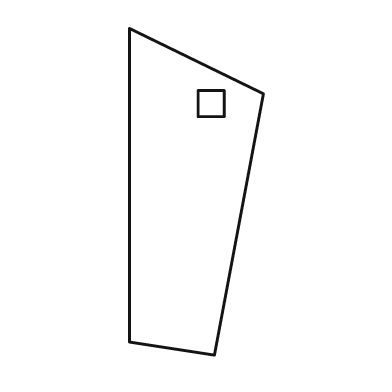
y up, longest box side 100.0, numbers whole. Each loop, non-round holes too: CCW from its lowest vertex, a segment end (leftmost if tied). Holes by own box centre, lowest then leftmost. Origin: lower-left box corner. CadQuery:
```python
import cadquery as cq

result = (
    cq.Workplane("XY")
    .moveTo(26.0, 0.0)
    .lineTo(41.0, 80.0)
    .lineTo(0.0, 100.0)
    .lineTo(0.0, 4.0)
    .close()
    .moveTo(21.0, 73.0)
    .lineTo(29.0, 73.0)
    .lineTo(29.0, 81.0)
    .lineTo(21.0, 81.0)
    .close()
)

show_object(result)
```